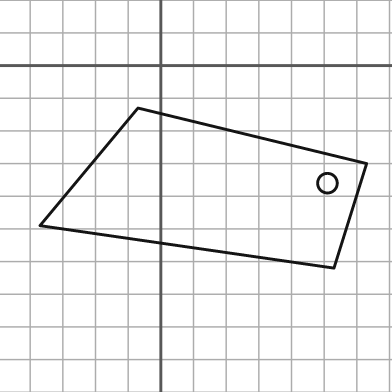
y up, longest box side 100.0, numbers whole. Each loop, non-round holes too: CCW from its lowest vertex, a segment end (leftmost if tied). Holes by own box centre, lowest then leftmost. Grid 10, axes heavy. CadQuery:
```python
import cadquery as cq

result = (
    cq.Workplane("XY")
    .moveTo(53.0, -62.0)
    .lineTo(63.0, -30.0)
    .lineTo(-7.0, -13.0)
    .lineTo(-37.0, -49.0)
    .close()
    .moveTo(51.0, -36.0)
    .circle(3.0)
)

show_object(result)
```